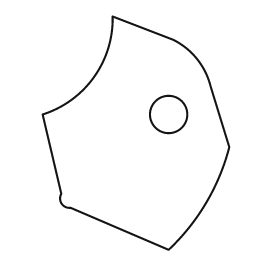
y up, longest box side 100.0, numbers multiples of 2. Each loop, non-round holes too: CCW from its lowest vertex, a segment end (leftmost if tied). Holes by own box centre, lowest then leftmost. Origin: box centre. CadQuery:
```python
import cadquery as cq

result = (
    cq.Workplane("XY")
    .moveTo(14.0, -50.0)
    .threePointArc((30.0, -30.0), (40.0, -6.0))
    .lineTo(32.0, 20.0)
    .threePointArc((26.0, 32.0), (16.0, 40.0))
    .lineTo(-10.0, 50.0)
    .threePointArc((-18.0, 24.0), (-40.0, 8.0))
    .lineTo(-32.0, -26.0)
    .threePointArc((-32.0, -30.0), (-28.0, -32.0))
    .close()
    .moveTo(14.0, 8.0)
    .circle(8.0)
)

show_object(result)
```